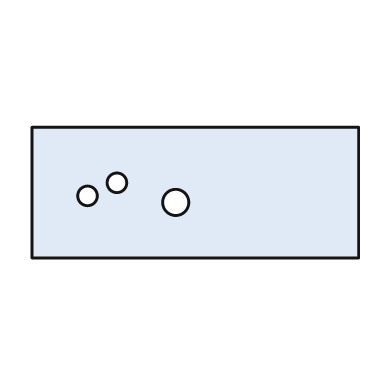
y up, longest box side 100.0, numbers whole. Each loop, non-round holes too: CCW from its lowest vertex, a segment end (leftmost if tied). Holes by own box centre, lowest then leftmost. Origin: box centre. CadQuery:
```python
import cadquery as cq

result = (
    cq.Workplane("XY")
    .moveTo(-50.0, -20.0)
    .lineTo(50.0, -20.0)
    .lineTo(50.0, 20.0)
    .lineTo(-50.0, 20.0)
    .close()
    .moveTo(-6.0, -3.0)
    .circle(4.0)
    .moveTo(-33.0, -1.0)
    .circle(3.0)
    .moveTo(-24.0, 3.0)
    .circle(3.0)
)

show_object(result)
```